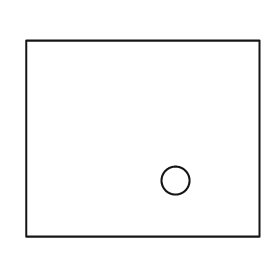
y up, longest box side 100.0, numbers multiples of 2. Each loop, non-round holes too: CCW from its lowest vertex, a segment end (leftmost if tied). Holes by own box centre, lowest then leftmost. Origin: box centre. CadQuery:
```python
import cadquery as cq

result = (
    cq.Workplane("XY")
    .moveTo(-50.0, -42.0)
    .lineTo(50.0, -42.0)
    .lineTo(50.0, 42.0)
    .lineTo(-50.0, 42.0)
    .close()
    .moveTo(14.0, -18.0)
    .circle(6.0)
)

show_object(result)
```